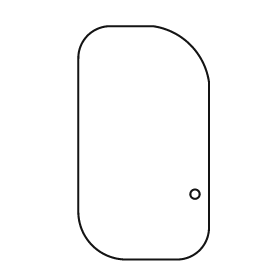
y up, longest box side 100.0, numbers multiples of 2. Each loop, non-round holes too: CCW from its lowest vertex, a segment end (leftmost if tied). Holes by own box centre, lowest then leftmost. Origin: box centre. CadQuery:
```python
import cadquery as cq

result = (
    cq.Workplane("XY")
    .moveTo(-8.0, -50.0)
    .lineTo(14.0, -50.0)
    .threePointArc((24.0, -46.0), (28.0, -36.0))
    .lineTo(28.0, 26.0)
    .threePointArc((20.0, 42.0), (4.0, 50.0))
    .lineTo(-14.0, 50.0)
    .threePointArc((-24.0, 46.0), (-28.0, 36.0))
    .lineTo(-28.0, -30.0)
    .threePointArc((-22.0, -44.0), (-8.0, -50.0))
    .close()
    .moveTo(22.0, -22.0)
    .circle(2.0)
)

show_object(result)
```